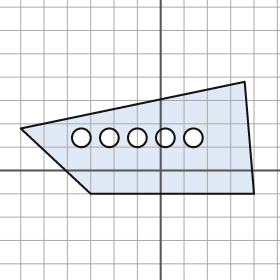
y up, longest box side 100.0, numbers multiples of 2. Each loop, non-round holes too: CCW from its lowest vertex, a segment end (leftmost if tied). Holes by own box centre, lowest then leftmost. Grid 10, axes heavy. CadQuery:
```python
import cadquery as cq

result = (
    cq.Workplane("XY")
    .moveTo(-30.0, -10.0)
    .lineTo(40.0, -10.0)
    .lineTo(36.0, 38.0)
    .lineTo(-60.0, 18.0)
    .close()
    .moveTo(-34.0, 14.0)
    .circle(4.0)
    .moveTo(-22.0, 14.0)
    .circle(4.0)
    .moveTo(-10.0, 14.0)
    .circle(4.0)
    .moveTo(2.0, 14.0)
    .circle(4.0)
    .moveTo(14.0, 14.0)
    .circle(4.0)
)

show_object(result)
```